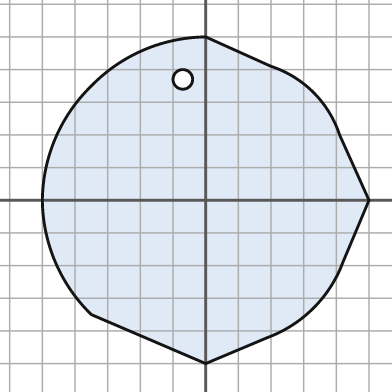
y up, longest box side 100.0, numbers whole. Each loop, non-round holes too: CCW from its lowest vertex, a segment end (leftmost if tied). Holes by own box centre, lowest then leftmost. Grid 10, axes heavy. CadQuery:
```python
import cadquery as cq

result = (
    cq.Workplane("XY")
    .moveTo(0.0, -50.0)
    .lineTo(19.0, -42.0)
    .threePointArc((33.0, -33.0), (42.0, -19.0))
    .lineTo(50.0, 0.0)
    .lineTo(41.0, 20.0)
    .threePointArc((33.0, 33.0), (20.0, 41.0))
    .lineTo(0.0, 50.0)
    .threePointArc((-19.0, 46.0), (-35.0, 35.0))
    .threePointArc((-46.0, 19.0), (-50.0, 0.0))
    .threePointArc((-46.0, -19.0), (-35.0, -35.0))
    .close()
    .moveTo(-7.0, 37.0)
    .circle(3.0)
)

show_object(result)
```